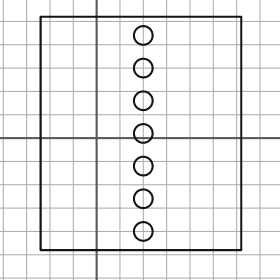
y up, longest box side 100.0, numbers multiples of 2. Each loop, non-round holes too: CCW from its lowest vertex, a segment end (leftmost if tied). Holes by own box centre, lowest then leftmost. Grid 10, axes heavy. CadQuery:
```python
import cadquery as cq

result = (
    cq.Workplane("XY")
    .moveTo(-24.0, -48.0)
    .lineTo(62.0, -48.0)
    .lineTo(62.0, 52.0)
    .lineTo(-24.0, 52.0)
    .close()
    .moveTo(20.0, -40.0)
    .circle(4.0)
    .moveTo(20.0, -26.0)
    .circle(4.0)
    .moveTo(20.0, -12.0)
    .circle(4.0)
    .moveTo(20.0, 2.0)
    .circle(4.0)
    .moveTo(20.0, 16.0)
    .circle(4.0)
    .moveTo(20.0, 30.0)
    .circle(4.0)
    .moveTo(20.0, 44.0)
    .circle(4.0)
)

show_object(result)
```